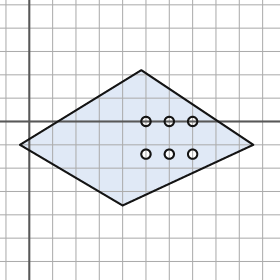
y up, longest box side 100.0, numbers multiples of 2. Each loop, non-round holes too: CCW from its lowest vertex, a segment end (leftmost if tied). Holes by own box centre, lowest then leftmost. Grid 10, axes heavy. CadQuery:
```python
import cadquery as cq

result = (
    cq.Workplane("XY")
    .moveTo(40.0, -36.0)
    .lineTo(96.0, -10.0)
    .lineTo(48.0, 22.0)
    .lineTo(-4.0, -10.0)
    .close()
    .moveTo(50.0, -14.0)
    .circle(2.0)
    .moveTo(60.0, -14.0)
    .circle(2.0)
    .moveTo(70.0, -14.0)
    .circle(2.0)
    .moveTo(50.0, 0.0)
    .circle(2.0)
    .moveTo(60.0, 0.0)
    .circle(2.0)
    .moveTo(70.0, 0.0)
    .circle(2.0)
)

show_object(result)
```